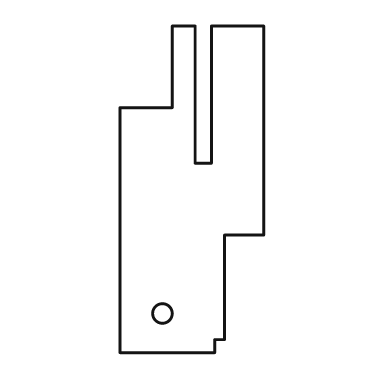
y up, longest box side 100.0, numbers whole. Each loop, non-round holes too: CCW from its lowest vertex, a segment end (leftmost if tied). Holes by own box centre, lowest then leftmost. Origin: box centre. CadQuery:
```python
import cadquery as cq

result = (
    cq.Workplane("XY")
    .moveTo(-22.0, -50.0)
    .lineTo(7.0, -50.0)
    .lineTo(7.0, -46.0)
    .lineTo(10.0, -46.0)
    .lineTo(10.0, -14.0)
    .lineTo(22.0, -14.0)
    .lineTo(22.0, 50.0)
    .lineTo(6.0, 50.0)
    .lineTo(6.0, 8.0)
    .lineTo(1.0, 8.0)
    .lineTo(1.0, 50.0)
    .lineTo(-6.0, 50.0)
    .lineTo(-6.0, 25.0)
    .lineTo(-22.0, 25.0)
    .close()
    .moveTo(-9.0, -38.0)
    .circle(3.0)
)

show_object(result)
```